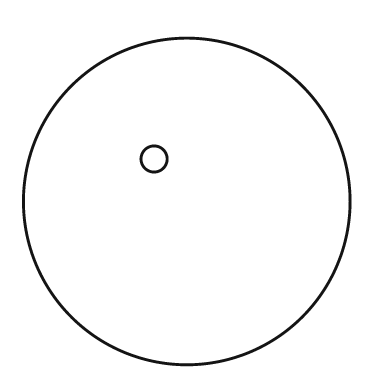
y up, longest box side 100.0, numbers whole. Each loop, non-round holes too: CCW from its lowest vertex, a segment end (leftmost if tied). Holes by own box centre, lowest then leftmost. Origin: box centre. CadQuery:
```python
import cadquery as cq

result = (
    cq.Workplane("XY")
    .moveTo(0.0, 0.0)
    .circle(50.0)
    .moveTo(-10.0, 13.0)
    .circle(4.0)
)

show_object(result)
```